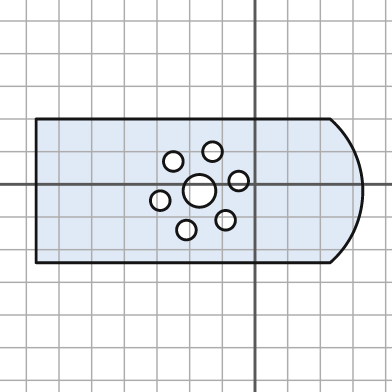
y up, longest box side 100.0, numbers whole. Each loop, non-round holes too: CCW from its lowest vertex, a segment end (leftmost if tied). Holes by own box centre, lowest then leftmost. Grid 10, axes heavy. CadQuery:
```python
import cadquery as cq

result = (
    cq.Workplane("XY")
    .moveTo(-67.0, -24.0)
    .lineTo(23.0, -24.0)
    .threePointArc((33.0, -2.0), (23.0, 20.0))
    .lineTo(-67.0, 20.0)
    .close()
    .moveTo(-21.0, -14.0)
    .circle(3.0)
    .moveTo(-9.0, -11.0)
    .circle(3.0)
    .moveTo(-29.0, -5.0)
    .circle(3.0)
    .moveTo(-17.0, -2.0)
    .circle(5.0)
    .moveTo(-5.0, 1.0)
    .circle(3.0)
    .moveTo(-25.0, 7.0)
    .circle(3.0)
    .moveTo(-13.0, 10.0)
    .circle(3.0)
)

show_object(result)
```